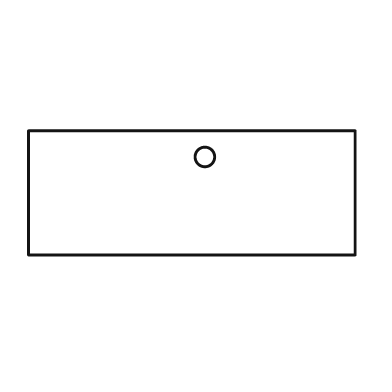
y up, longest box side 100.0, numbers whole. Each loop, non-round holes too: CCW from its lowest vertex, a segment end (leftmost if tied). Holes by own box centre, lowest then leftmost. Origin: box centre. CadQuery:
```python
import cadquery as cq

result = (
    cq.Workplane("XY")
    .moveTo(-50.0, -19.0)
    .lineTo(50.0, -19.0)
    .lineTo(50.0, 19.0)
    .lineTo(-50.0, 19.0)
    .close()
    .moveTo(4.0, 11.0)
    .circle(3.0)
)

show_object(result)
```